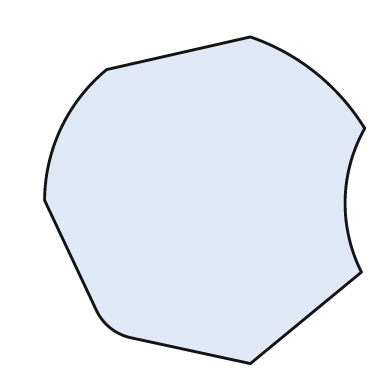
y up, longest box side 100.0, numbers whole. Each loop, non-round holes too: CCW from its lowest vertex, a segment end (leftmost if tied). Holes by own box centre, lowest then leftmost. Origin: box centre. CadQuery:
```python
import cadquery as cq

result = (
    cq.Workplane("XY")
    .moveTo(14.0, -50.0)
    .lineTo(48.0, -22.0)
    .threePointArc((43.0, 0.0), (49.0, 22.0))
    .threePointArc((34.0, 39.0), (14.0, 50.0))
    .lineTo(-30.0, 40.0)
    .threePointArc((-44.0, 22.0), (-49.0, 0.0))
    .lineTo(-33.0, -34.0)
    .threePointArc((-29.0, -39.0), (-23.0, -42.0))
    .close()
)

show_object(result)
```